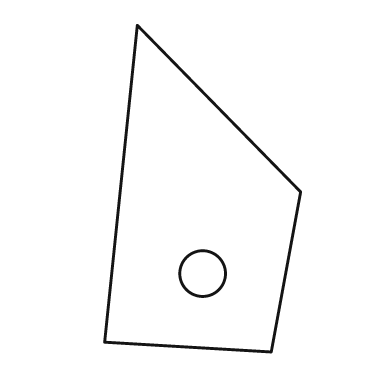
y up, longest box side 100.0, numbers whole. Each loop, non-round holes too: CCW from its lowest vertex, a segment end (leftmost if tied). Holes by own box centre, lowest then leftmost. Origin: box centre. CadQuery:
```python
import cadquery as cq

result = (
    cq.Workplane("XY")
    .moveTo(21.0, -50.0)
    .lineTo(30.0, -1.0)
    .lineTo(-20.0, 50.0)
    .lineTo(-30.0, -47.0)
    .close()
    .moveTo(0.0, -26.0)
    .circle(7.0)
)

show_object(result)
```